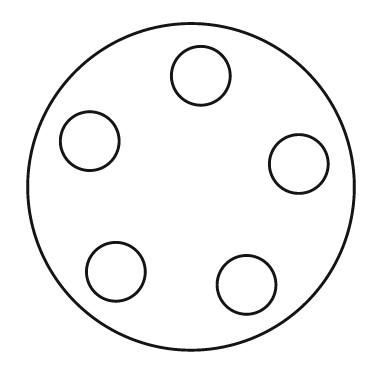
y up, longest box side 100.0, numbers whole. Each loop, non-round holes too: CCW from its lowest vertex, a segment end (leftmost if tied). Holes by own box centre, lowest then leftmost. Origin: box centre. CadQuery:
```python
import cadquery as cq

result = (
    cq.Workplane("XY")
    .moveTo(0.0, 0.0)
    .circle(50.0)
    .moveTo(17.0, -30.0)
    .circle(9.0)
    .moveTo(-23.0, -26.0)
    .circle(9.0)
    .moveTo(33.0, 7.0)
    .circle(9.0)
    .moveTo(-31.0, 14.0)
    .circle(9.0)
    .moveTo(3.0, 34.0)
    .circle(9.0)
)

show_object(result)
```